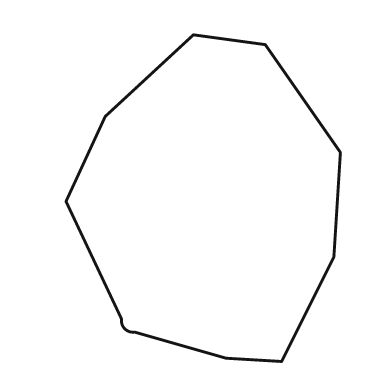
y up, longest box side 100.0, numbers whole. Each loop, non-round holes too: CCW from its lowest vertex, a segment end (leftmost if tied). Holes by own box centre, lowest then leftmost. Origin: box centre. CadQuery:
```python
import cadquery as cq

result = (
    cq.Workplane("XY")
    .moveTo(24.0, -50.0)
    .lineTo(40.0, -18.0)
    .lineTo(42.0, 14.0)
    .lineTo(19.0, 47.0)
    .lineTo(-3.0, 50.0)
    .lineTo(-30.0, 25.0)
    .lineTo(-42.0, -1.0)
    .lineTo(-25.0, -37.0)
    .threePointArc((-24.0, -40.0), (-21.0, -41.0))
    .lineTo(7.0, -49.0)
    .close()
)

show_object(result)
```